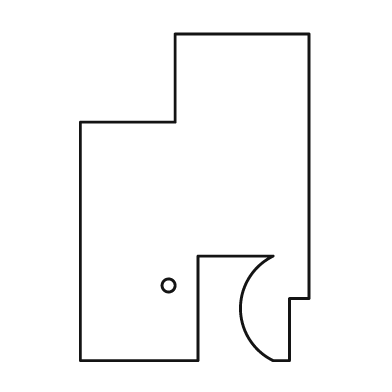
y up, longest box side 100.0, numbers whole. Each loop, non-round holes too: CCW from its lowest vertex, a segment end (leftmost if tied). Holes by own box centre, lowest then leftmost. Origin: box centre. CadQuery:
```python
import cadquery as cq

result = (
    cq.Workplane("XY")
    .moveTo(-35.0, -50.0)
    .lineTo(1.0, -50.0)
    .lineTo(1.0, -18.0)
    .lineTo(24.0, -18.0)
    .threePointArc((14.0, -34.0), (24.0, -50.0))
    .lineTo(29.0, -50.0)
    .lineTo(29.0, -31.0)
    .lineTo(35.0, -31.0)
    .lineTo(35.0, 50.0)
    .lineTo(-6.0, 50.0)
    .lineTo(-6.0, 23.0)
    .lineTo(-35.0, 23.0)
    .close()
    .moveTo(-8.0, -27.0)
    .circle(2.0)
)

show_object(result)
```